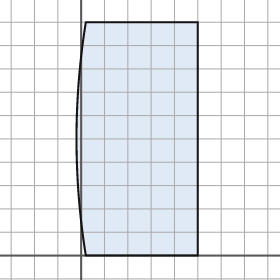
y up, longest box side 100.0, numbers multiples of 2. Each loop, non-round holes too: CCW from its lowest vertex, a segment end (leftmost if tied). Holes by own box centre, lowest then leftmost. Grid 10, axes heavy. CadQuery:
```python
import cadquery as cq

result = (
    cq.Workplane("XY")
    .moveTo(2.0, 0.0)
    .lineTo(50.0, 0.0)
    .lineTo(50.0, 100.0)
    .lineTo(2.0, 100.0)
    .threePointArc((-2.0, 50.0), (2.0, 0.0))
    .close()
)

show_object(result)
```